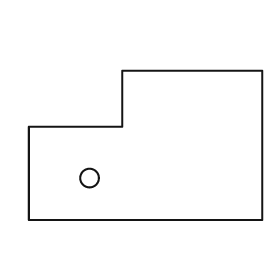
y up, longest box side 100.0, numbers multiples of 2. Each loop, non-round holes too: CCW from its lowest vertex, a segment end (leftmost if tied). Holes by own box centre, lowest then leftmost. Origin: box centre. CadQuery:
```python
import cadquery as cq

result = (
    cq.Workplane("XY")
    .moveTo(-50.0, -32.0)
    .lineTo(50.0, -32.0)
    .lineTo(50.0, 32.0)
    .lineTo(-10.0, 32.0)
    .lineTo(-10.0, 8.0)
    .lineTo(-50.0, 8.0)
    .close()
    .moveTo(-24.0, -14.0)
    .circle(4.0)
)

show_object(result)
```